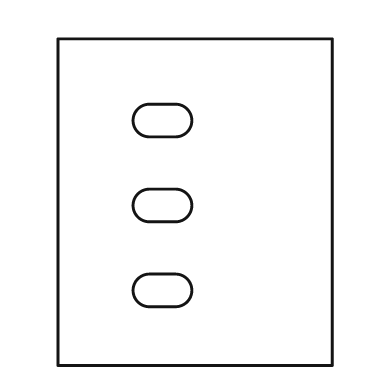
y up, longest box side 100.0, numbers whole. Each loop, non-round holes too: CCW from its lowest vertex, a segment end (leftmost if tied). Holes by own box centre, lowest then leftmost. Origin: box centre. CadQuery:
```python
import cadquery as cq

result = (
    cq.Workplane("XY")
    .moveTo(-42.0, -50.0)
    .lineTo(42.0, -50.0)
    .lineTo(42.0, 50.0)
    .lineTo(-42.0, 50.0)
    .close()
    .moveTo(-14.0, -32.0)
    .lineTo(-6.0, -32.0)
    .threePointArc((-1.0, -27.0), (-6.0, -22.0))
    .lineTo(-14.0, -22.0)
    .threePointArc((-19.0, -27.0), (-14.0, -32.0))
    .close()
    .moveTo(-14.0, -6.0)
    .lineTo(-6.0, -6.0)
    .threePointArc((-1.0, -1.0), (-6.0, 4.0))
    .lineTo(-14.0, 4.0)
    .threePointArc((-19.0, -1.0), (-14.0, -6.0))
    .close()
    .moveTo(-14.0, 20.0)
    .lineTo(-6.0, 20.0)
    .threePointArc((-1.0, 25.0), (-6.0, 30.0))
    .lineTo(-14.0, 30.0)
    .threePointArc((-19.0, 25.0), (-14.0, 20.0))
    .close()
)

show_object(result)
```